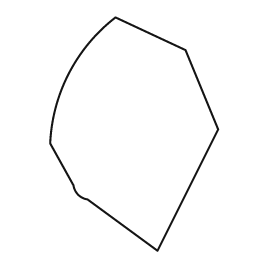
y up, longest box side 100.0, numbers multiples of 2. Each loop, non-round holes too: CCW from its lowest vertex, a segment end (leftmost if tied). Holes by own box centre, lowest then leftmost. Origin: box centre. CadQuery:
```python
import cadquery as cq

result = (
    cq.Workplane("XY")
    .moveTo(10.0, -50.0)
    .lineTo(36.0, 2.0)
    .lineTo(22.0, 36.0)
    .lineTo(-8.0, 50.0)
    .threePointArc((-28.0, 26.0), (-36.0, -4.0))
    .lineTo(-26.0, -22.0)
    .threePointArc((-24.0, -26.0), (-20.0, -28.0))
    .close()
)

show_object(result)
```